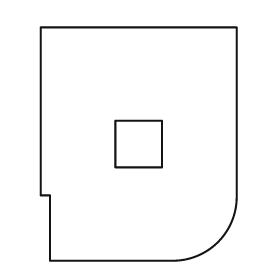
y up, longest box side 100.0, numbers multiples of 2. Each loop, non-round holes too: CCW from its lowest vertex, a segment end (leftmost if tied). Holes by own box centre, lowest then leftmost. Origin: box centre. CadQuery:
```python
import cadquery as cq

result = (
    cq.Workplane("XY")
    .moveTo(-38.0, -50.0)
    .lineTo(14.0, -50.0)
    .threePointArc((34.0, -42.0), (42.0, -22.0))
    .lineTo(42.0, 50.0)
    .lineTo(-42.0, 50.0)
    .lineTo(-42.0, -22.0)
    .lineTo(-38.0, -22.0)
    .close()
    .moveTo(-10.0, -10.0)
    .lineTo(10.0, -10.0)
    .lineTo(10.0, 10.0)
    .lineTo(-10.0, 10.0)
    .close()
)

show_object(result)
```